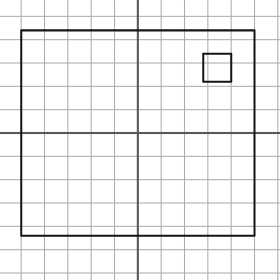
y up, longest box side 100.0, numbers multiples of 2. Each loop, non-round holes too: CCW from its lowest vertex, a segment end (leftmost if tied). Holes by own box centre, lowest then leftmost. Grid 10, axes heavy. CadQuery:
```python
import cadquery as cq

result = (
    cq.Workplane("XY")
    .moveTo(-50.0, -44.0)
    .lineTo(50.0, -44.0)
    .lineTo(50.0, 44.0)
    .lineTo(-50.0, 44.0)
    .close()
    .moveTo(28.0, 22.0)
    .lineTo(40.0, 22.0)
    .lineTo(40.0, 34.0)
    .lineTo(28.0, 34.0)
    .close()
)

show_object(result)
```